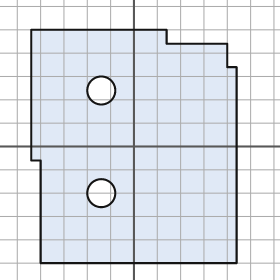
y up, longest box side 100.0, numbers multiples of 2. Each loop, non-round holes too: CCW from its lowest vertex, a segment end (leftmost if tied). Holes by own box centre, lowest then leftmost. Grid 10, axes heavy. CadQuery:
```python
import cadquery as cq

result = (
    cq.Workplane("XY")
    .moveTo(-40.0, -50.0)
    .lineTo(44.0, -50.0)
    .lineTo(44.0, 34.0)
    .lineTo(40.0, 34.0)
    .lineTo(40.0, 44.0)
    .lineTo(14.0, 44.0)
    .lineTo(14.0, 50.0)
    .lineTo(-44.0, 50.0)
    .lineTo(-44.0, -6.0)
    .lineTo(-40.0, -6.0)
    .close()
    .moveTo(-14.0, -20.0)
    .circle(6.0)
    .moveTo(-14.0, 24.0)
    .circle(6.0)
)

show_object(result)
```